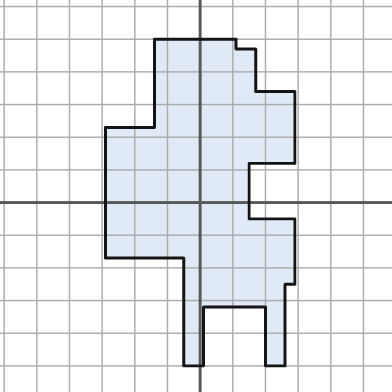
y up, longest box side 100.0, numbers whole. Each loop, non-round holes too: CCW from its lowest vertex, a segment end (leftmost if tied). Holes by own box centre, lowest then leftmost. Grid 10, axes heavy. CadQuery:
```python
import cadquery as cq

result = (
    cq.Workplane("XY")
    .moveTo(-5.0, -50.0)
    .lineTo(1.0, -50.0)
    .lineTo(1.0, -32.0)
    .lineTo(20.0, -32.0)
    .lineTo(20.0, -50.0)
    .lineTo(26.0, -50.0)
    .lineTo(26.0, -25.0)
    .lineTo(29.0, -25.0)
    .lineTo(29.0, -5.0)
    .lineTo(15.0, -5.0)
    .lineTo(15.0, 12.0)
    .lineTo(29.0, 12.0)
    .lineTo(29.0, 34.0)
    .lineTo(17.0, 34.0)
    .lineTo(17.0, 47.0)
    .lineTo(11.0, 47.0)
    .lineTo(11.0, 50.0)
    .lineTo(-14.0, 50.0)
    .lineTo(-14.0, 23.0)
    .lineTo(-29.0, 23.0)
    .lineTo(-29.0, -17.0)
    .lineTo(-5.0, -17.0)
    .close()
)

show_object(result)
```